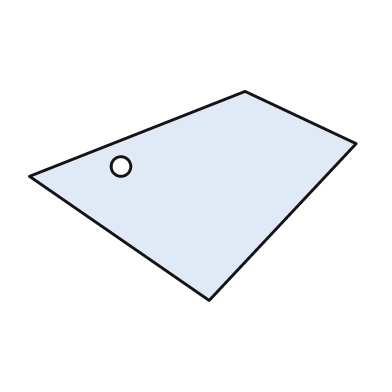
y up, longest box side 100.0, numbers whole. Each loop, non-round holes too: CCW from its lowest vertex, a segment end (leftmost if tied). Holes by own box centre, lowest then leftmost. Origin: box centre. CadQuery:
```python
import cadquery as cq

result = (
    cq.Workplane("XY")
    .moveTo(5.0, -32.0)
    .lineTo(50.0, 16.0)
    .lineTo(16.0, 32.0)
    .lineTo(-50.0, 6.0)
    .close()
    .moveTo(-22.0, 9.0)
    .circle(3.0)
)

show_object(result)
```